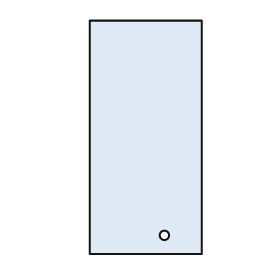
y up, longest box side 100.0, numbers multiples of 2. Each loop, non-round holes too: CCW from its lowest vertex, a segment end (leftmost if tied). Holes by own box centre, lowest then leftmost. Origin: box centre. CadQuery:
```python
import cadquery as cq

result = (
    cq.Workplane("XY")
    .moveTo(-24.0, -50.0)
    .lineTo(24.0, -50.0)
    .lineTo(24.0, 50.0)
    .lineTo(-24.0, 50.0)
    .close()
    .moveTo(8.0, -42.0)
    .circle(2.0)
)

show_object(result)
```